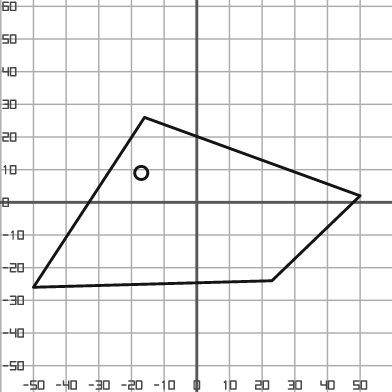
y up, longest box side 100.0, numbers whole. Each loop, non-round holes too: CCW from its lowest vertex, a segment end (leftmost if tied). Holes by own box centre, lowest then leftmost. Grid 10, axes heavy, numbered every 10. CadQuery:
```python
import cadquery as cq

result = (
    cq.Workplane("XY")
    .moveTo(-50.0, -26.0)
    .lineTo(23.0, -24.0)
    .lineTo(50.0, 2.0)
    .lineTo(-16.0, 26.0)
    .close()
    .moveTo(-17.0, 9.0)
    .circle(2.0)
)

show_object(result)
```